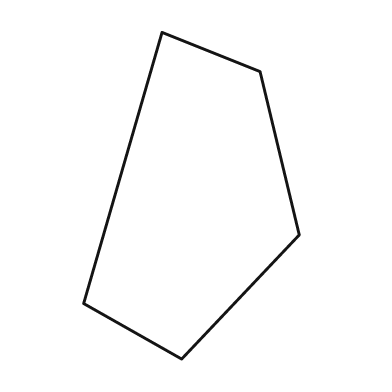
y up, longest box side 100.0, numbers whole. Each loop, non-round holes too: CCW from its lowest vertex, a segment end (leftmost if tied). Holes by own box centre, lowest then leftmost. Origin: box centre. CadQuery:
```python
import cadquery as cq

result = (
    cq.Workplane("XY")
    .moveTo(-3.0, -50.0)
    .lineTo(33.0, -12.0)
    .lineTo(21.0, 38.0)
    .lineTo(-9.0, 50.0)
    .lineTo(-33.0, -33.0)
    .close()
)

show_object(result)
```